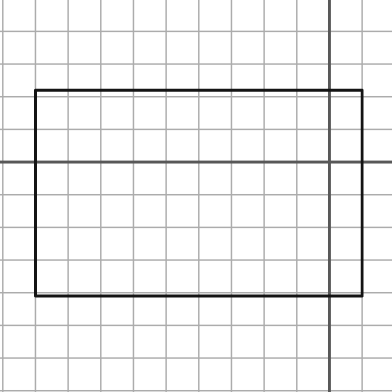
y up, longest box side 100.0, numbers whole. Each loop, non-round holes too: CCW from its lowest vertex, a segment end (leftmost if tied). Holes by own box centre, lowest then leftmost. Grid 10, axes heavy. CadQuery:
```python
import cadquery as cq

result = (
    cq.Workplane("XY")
    .moveTo(-90.0, -41.0)
    .lineTo(10.0, -41.0)
    .lineTo(10.0, 22.0)
    .lineTo(-90.0, 22.0)
    .close()
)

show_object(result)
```